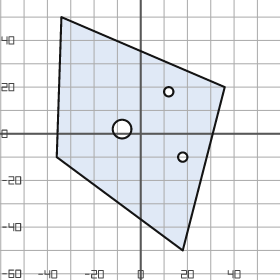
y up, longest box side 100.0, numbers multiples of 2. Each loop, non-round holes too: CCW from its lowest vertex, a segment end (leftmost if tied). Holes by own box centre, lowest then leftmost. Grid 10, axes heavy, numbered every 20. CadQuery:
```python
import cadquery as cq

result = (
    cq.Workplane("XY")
    .moveTo(18.0, -50.0)
    .lineTo(36.0, 20.0)
    .lineTo(-34.0, 50.0)
    .lineTo(-36.0, -10.0)
    .close()
    .moveTo(18.0, -10.0)
    .circle(2.0)
    .moveTo(-8.0, 2.0)
    .circle(4.0)
    .moveTo(12.0, 18.0)
    .circle(2.0)
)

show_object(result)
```